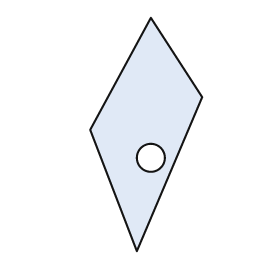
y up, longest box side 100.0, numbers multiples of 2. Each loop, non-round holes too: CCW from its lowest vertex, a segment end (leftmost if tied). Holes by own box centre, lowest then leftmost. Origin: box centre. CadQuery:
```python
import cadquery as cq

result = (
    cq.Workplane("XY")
    .moveTo(-4.0, -50.0)
    .lineTo(24.0, 16.0)
    .lineTo(2.0, 50.0)
    .lineTo(-24.0, 2.0)
    .close()
    .moveTo(2.0, -10.0)
    .circle(6.0)
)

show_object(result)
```